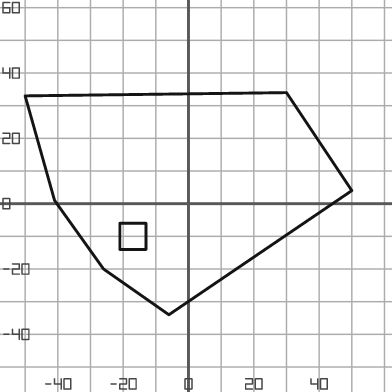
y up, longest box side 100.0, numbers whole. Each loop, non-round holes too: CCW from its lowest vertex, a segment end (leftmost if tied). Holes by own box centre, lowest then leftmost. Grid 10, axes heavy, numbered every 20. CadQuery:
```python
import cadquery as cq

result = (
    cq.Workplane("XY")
    .moveTo(-6.0, -34.0)
    .lineTo(50.0, 4.0)
    .lineTo(30.0, 34.0)
    .lineTo(-50.0, 33.0)
    .lineTo(-41.0, 1.0)
    .lineTo(-26.0, -20.0)
    .close()
    .moveTo(-21.0, -14.0)
    .lineTo(-13.0, -14.0)
    .lineTo(-13.0, -6.0)
    .lineTo(-21.0, -6.0)
    .close()
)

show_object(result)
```